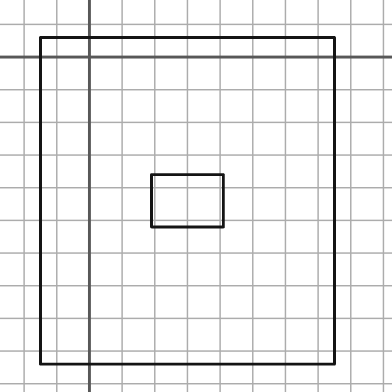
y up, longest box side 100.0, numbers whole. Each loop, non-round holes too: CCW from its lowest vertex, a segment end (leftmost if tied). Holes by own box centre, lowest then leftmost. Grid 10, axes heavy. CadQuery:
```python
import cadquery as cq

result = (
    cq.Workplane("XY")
    .moveTo(-15.0, -94.0)
    .lineTo(75.0, -94.0)
    .lineTo(75.0, 6.0)
    .lineTo(-15.0, 6.0)
    .close()
    .moveTo(19.0, -52.0)
    .lineTo(41.0, -52.0)
    .lineTo(41.0, -36.0)
    .lineTo(19.0, -36.0)
    .close()
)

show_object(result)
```